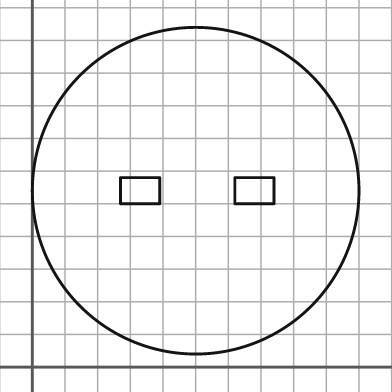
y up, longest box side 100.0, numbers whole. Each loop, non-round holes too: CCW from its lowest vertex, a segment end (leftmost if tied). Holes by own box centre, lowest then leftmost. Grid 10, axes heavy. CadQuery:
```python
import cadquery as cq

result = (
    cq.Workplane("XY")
    .moveTo(50.0, 54.0)
    .circle(50.0)
    .moveTo(27.0, 50.0)
    .lineTo(39.0, 50.0)
    .lineTo(39.0, 58.0)
    .lineTo(27.0, 58.0)
    .close()
    .moveTo(62.0, 50.0)
    .lineTo(74.0, 50.0)
    .lineTo(74.0, 58.0)
    .lineTo(62.0, 58.0)
    .close()
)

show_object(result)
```